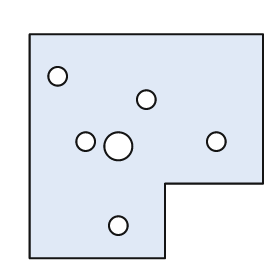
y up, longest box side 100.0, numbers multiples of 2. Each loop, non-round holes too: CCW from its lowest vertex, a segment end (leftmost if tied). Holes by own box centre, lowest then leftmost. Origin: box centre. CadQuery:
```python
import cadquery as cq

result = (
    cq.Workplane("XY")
    .moveTo(-50.0, -48.0)
    .lineTo(8.0, -48.0)
    .lineTo(8.0, -16.0)
    .lineTo(50.0, -16.0)
    .lineTo(50.0, 48.0)
    .lineTo(-50.0, 48.0)
    .close()
    .moveTo(-12.0, -34.0)
    .circle(4.0)
    .moveTo(-12.0, 0.0)
    .circle(6.0)
    .moveTo(-26.0, 2.0)
    .circle(4.0)
    .moveTo(30.0, 2.0)
    .circle(4.0)
    .moveTo(0.0, 20.0)
    .circle(4.0)
    .moveTo(-38.0, 30.0)
    .circle(4.0)
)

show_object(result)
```